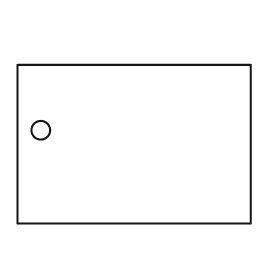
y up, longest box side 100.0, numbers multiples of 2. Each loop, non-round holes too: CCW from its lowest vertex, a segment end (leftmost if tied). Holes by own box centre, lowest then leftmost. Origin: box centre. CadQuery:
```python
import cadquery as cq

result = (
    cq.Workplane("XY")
    .moveTo(-50.0, -34.0)
    .lineTo(50.0, -34.0)
    .lineTo(50.0, 34.0)
    .lineTo(-50.0, 34.0)
    .close()
    .moveTo(-40.0, 6.0)
    .circle(4.0)
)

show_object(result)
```